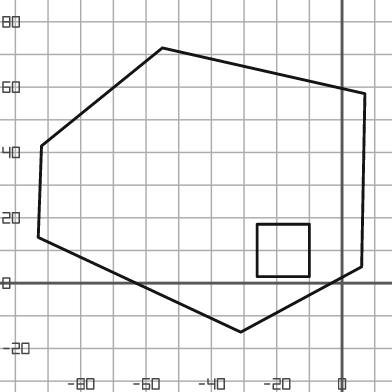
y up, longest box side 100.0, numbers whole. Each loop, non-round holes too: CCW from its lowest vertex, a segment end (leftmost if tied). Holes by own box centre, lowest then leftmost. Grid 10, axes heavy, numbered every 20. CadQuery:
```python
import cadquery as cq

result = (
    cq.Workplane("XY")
    .moveTo(-31.0, -15.0)
    .lineTo(6.0, 5.0)
    .lineTo(7.0, 58.0)
    .lineTo(-55.0, 72.0)
    .lineTo(-92.0, 42.0)
    .lineTo(-93.0, 14.0)
    .close()
    .moveTo(-26.0, 2.0)
    .lineTo(-10.0, 2.0)
    .lineTo(-10.0, 18.0)
    .lineTo(-26.0, 18.0)
    .close()
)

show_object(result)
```